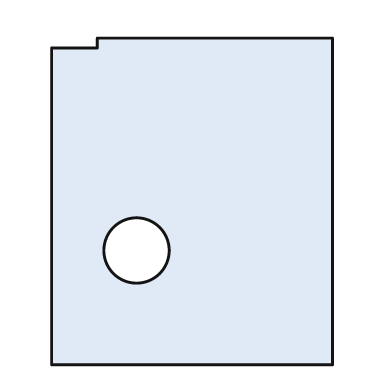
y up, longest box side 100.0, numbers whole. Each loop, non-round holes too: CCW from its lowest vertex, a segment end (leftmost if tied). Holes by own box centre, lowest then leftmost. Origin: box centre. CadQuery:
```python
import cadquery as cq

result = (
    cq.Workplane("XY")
    .moveTo(-43.0, -50.0)
    .lineTo(43.0, -50.0)
    .lineTo(43.0, 50.0)
    .lineTo(-29.0, 50.0)
    .lineTo(-29.0, 47.0)
    .lineTo(-43.0, 47.0)
    .close()
    .moveTo(-17.0, -15.0)
    .circle(10.0)
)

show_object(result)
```